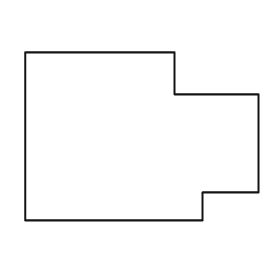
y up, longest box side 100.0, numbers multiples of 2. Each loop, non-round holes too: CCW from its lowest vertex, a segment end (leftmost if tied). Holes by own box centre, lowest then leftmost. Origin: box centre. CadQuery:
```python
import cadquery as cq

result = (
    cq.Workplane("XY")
    .moveTo(-50.0, -36.0)
    .lineTo(26.0, -36.0)
    .lineTo(26.0, -24.0)
    .lineTo(50.0, -24.0)
    .lineTo(50.0, 18.0)
    .lineTo(14.0, 18.0)
    .lineTo(14.0, 36.0)
    .lineTo(-50.0, 36.0)
    .close()
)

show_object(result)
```